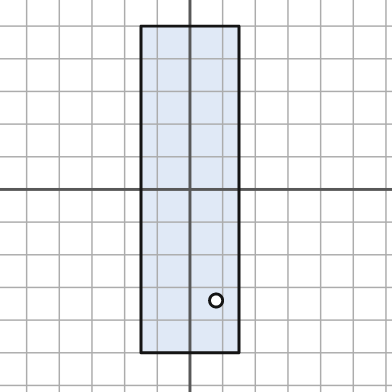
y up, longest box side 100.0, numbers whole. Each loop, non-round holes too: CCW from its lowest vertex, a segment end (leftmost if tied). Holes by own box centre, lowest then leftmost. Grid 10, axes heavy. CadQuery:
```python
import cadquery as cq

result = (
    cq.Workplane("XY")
    .moveTo(-15.0, -50.0)
    .lineTo(15.0, -50.0)
    .lineTo(15.0, 50.0)
    .lineTo(-15.0, 50.0)
    .close()
    .moveTo(8.0, -34.0)
    .circle(2.0)
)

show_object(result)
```